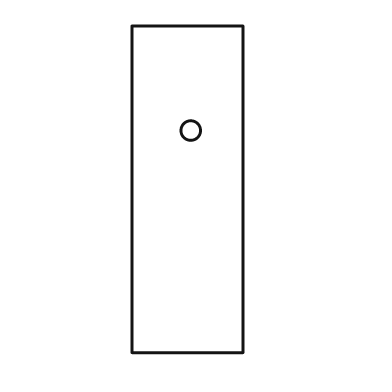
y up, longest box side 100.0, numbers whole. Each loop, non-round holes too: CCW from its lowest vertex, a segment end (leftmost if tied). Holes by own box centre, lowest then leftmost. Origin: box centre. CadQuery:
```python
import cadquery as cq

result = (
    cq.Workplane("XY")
    .moveTo(-17.0, -50.0)
    .lineTo(17.0, -50.0)
    .lineTo(17.0, 50.0)
    .lineTo(-17.0, 50.0)
    .close()
    .moveTo(1.0, 18.0)
    .circle(3.0)
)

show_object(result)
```